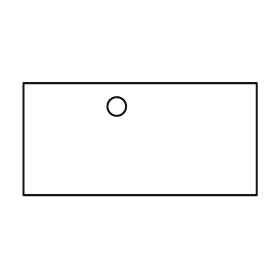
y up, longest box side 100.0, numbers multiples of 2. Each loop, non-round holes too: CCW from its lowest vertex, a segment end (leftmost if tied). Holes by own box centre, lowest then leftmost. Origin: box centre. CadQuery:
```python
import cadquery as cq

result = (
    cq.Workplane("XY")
    .moveTo(-50.0, -24.0)
    .lineTo(50.0, -24.0)
    .lineTo(50.0, 24.0)
    .lineTo(-50.0, 24.0)
    .close()
    .moveTo(-10.0, 14.0)
    .circle(4.0)
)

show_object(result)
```